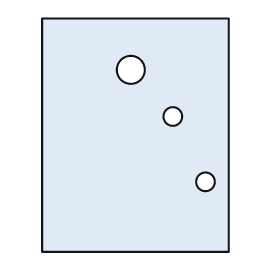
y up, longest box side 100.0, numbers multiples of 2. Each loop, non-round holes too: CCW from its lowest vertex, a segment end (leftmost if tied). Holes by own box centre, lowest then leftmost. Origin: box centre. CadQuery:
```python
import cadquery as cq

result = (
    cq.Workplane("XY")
    .moveTo(-40.0, -50.0)
    .lineTo(40.0, -50.0)
    .lineTo(40.0, 50.0)
    .lineTo(-40.0, 50.0)
    .close()
    .moveTo(30.0, -20.0)
    .circle(4.0)
    .moveTo(16.0, 8.0)
    .circle(4.0)
    .moveTo(-2.0, 28.0)
    .circle(6.0)
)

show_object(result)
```